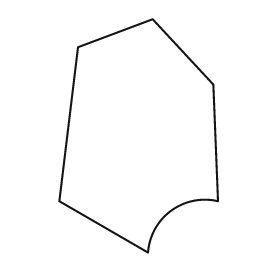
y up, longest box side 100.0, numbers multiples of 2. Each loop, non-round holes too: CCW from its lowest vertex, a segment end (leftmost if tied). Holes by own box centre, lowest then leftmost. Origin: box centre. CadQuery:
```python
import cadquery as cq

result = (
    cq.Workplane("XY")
    .moveTo(4.0, -50.0)
    .threePointArc((14.0, -32.0), (34.0, -28.0))
    .lineTo(32.0, 22.0)
    .lineTo(6.0, 50.0)
    .lineTo(-26.0, 38.0)
    .lineTo(-34.0, -28.0)
    .close()
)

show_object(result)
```